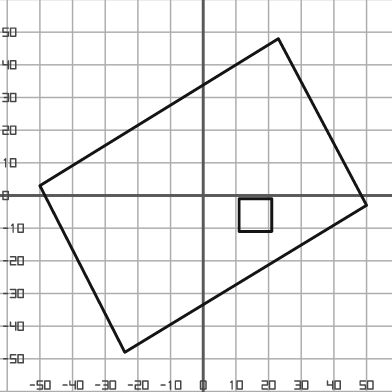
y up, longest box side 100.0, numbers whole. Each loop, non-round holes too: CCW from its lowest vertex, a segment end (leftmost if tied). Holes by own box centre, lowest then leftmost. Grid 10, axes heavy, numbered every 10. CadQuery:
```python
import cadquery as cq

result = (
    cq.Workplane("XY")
    .moveTo(-24.0, -48.0)
    .lineTo(50.0, -3.0)
    .lineTo(23.0, 48.0)
    .lineTo(-50.0, 3.0)
    .close()
    .moveTo(11.0, -11.0)
    .lineTo(21.0, -11.0)
    .lineTo(21.0, -1.0)
    .lineTo(11.0, -1.0)
    .close()
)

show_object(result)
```